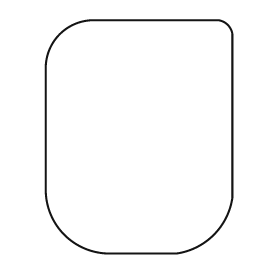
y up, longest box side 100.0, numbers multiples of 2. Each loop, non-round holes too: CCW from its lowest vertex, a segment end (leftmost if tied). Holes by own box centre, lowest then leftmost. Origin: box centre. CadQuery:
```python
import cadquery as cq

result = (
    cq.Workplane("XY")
    .moveTo(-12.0, -50.0)
    .lineTo(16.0, -50.0)
    .threePointArc((32.0, -42.0), (40.0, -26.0))
    .lineTo(40.0, 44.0)
    .threePointArc((38.0, 48.0), (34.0, 50.0))
    .lineTo(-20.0, 50.0)
    .threePointArc((-34.0, 44.0), (-40.0, 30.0))
    .lineTo(-40.0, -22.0)
    .threePointArc((-32.0, -42.0), (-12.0, -50.0))
    .close()
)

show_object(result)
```